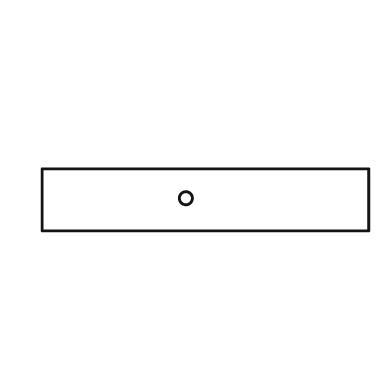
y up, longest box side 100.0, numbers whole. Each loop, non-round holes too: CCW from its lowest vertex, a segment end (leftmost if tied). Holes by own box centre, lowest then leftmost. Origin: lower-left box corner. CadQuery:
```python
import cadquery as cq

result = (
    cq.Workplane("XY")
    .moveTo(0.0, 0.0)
    .lineTo(100.0, 0.0)
    .lineTo(100.0, 19.0)
    .lineTo(0.0, 19.0)
    .close()
    .moveTo(44.0, 10.0)
    .circle(2.0)
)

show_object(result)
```